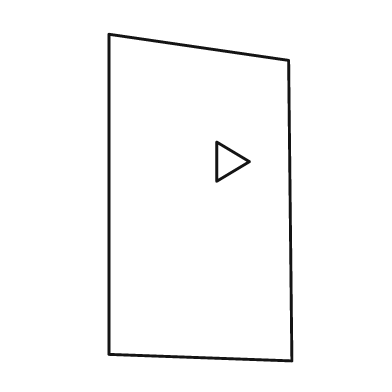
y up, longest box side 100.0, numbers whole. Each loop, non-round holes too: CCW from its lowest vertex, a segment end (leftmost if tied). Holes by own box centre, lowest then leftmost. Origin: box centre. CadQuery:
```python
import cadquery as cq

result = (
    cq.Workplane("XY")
    .moveTo(28.0, -50.0)
    .lineTo(27.0, 42.0)
    .lineTo(-28.0, 50.0)
    .lineTo(-28.0, -48.0)
    .close()
    .moveTo(5.0, 5.0)
    .lineTo(15.0, 11.0)
    .lineTo(5.0, 17.0)
    .close()
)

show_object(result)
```